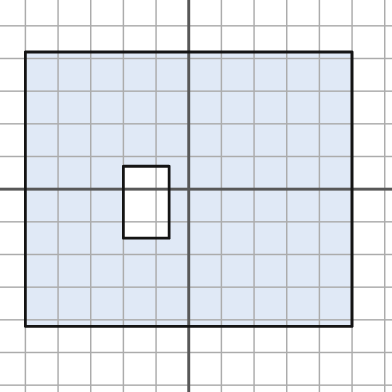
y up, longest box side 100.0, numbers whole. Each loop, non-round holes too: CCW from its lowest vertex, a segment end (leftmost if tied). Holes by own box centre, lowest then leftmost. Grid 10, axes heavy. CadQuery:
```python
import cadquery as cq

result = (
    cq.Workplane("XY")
    .moveTo(-50.0, -42.0)
    .lineTo(50.0, -42.0)
    .lineTo(50.0, 42.0)
    .lineTo(-50.0, 42.0)
    .close()
    .moveTo(-20.0, -15.0)
    .lineTo(-6.0, -15.0)
    .lineTo(-6.0, 7.0)
    .lineTo(-20.0, 7.0)
    .close()
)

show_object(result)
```